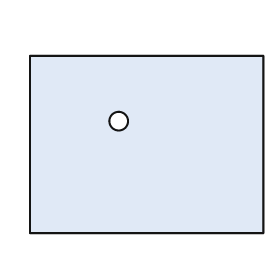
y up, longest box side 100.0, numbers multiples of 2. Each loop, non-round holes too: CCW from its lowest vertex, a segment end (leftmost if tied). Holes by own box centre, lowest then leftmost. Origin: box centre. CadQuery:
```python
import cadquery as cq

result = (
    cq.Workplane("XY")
    .moveTo(-50.0, -38.0)
    .lineTo(50.0, -38.0)
    .lineTo(50.0, 38.0)
    .lineTo(-50.0, 38.0)
    .close()
    .moveTo(-12.0, 10.0)
    .circle(4.0)
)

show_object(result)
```